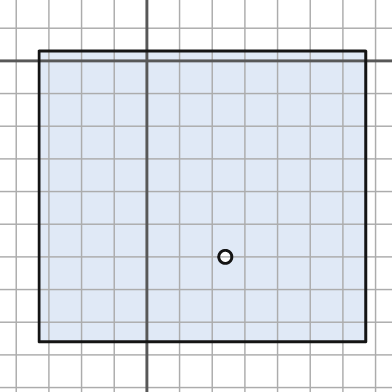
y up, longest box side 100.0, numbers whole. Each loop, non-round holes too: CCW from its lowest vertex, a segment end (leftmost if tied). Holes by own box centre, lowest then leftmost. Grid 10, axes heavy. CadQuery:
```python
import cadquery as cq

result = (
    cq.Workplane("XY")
    .moveTo(-33.0, -86.0)
    .lineTo(67.0, -86.0)
    .lineTo(67.0, 3.0)
    .lineTo(-33.0, 3.0)
    .close()
    .moveTo(24.0, -60.0)
    .circle(2.0)
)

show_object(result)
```